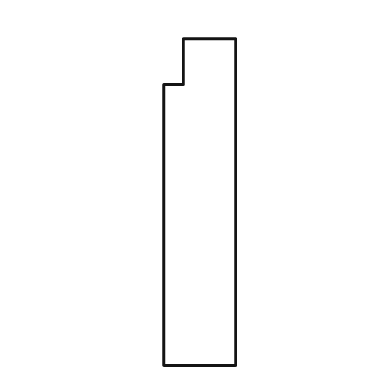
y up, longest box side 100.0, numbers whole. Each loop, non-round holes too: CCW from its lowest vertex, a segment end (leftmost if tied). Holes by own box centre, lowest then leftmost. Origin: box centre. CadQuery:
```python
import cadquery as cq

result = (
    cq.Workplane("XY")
    .moveTo(-11.0, -50.0)
    .lineTo(11.0, -50.0)
    .lineTo(11.0, 50.0)
    .lineTo(-5.0, 50.0)
    .lineTo(-5.0, 36.0)
    .lineTo(-11.0, 36.0)
    .close()
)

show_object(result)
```